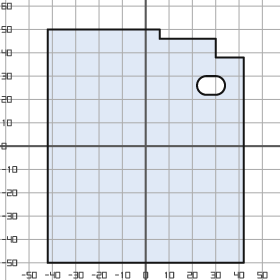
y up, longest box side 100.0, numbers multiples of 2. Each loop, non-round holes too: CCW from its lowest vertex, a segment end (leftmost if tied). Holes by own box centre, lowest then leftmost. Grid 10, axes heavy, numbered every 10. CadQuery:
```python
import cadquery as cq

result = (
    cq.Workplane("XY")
    .moveTo(-42.0, -50.0)
    .lineTo(42.0, -50.0)
    .lineTo(42.0, 38.0)
    .lineTo(30.0, 38.0)
    .lineTo(30.0, 46.0)
    .lineTo(6.0, 46.0)
    .lineTo(6.0, 50.0)
    .lineTo(-42.0, 50.0)
    .close()
    .moveTo(26.0, 22.0)
    .lineTo(30.0, 22.0)
    .threePointArc((34.0, 26.0), (30.0, 30.0))
    .lineTo(26.0, 30.0)
    .threePointArc((22.0, 26.0), (26.0, 22.0))
    .close()
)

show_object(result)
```